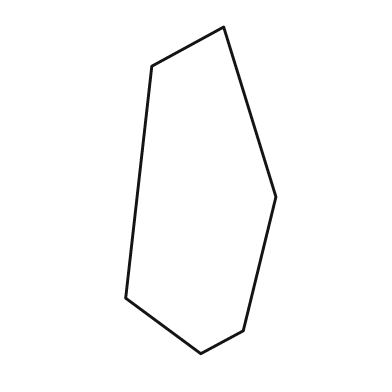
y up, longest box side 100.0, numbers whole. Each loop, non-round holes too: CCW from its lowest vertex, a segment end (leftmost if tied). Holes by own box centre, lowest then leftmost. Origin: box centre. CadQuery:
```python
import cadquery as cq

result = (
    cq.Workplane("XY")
    .moveTo(0.0, -50.0)
    .lineTo(13.0, -43.0)
    .lineTo(23.0, -2.0)
    .lineTo(7.0, 50.0)
    .lineTo(-15.0, 38.0)
    .lineTo(-23.0, -33.0)
    .close()
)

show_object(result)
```